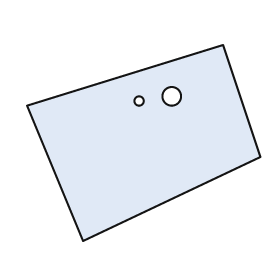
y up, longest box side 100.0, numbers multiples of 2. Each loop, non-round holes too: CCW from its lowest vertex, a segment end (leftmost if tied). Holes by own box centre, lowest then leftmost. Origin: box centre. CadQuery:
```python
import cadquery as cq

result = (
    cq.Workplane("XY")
    .moveTo(-26.0, -42.0)
    .lineTo(50.0, -6.0)
    .lineTo(34.0, 42.0)
    .lineTo(-50.0, 16.0)
    .close()
    .moveTo(-2.0, 18.0)
    .circle(2.0)
    .moveTo(12.0, 20.0)
    .circle(4.0)
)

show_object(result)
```